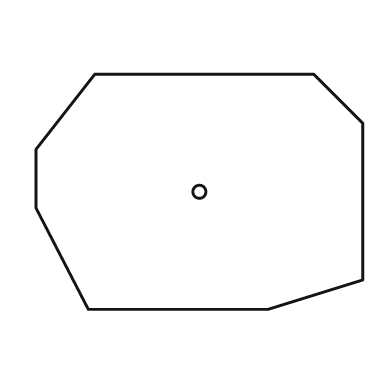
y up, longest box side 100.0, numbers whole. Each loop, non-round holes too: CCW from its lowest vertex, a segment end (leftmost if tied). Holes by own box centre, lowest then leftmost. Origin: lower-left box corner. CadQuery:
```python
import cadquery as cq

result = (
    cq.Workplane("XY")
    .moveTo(16.0, 0.0)
    .lineTo(71.0, 0.0)
    .lineTo(100.0, 9.0)
    .lineTo(100.0, 57.0)
    .lineTo(85.0, 72.0)
    .lineTo(18.0, 72.0)
    .lineTo(0.0, 49.0)
    .lineTo(0.0, 31.0)
    .close()
    .moveTo(50.0, 36.0)
    .circle(2.0)
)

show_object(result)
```